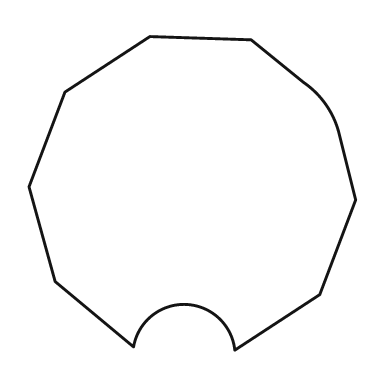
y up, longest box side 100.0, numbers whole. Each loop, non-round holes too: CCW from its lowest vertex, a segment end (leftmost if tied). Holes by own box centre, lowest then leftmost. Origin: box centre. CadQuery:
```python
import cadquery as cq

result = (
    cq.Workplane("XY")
    .moveTo(13.0, -48.0)
    .lineTo(39.0, -31.0)
    .lineTo(50.0, -2.0)
    .lineTo(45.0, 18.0)
    .threePointArc((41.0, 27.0), (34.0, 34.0))
    .lineTo(18.0, 47.0)
    .lineTo(-13.0, 48.0)
    .lineTo(-39.0, 31.0)
    .lineTo(-50.0, 2.0)
    .lineTo(-42.0, -27.0)
    .lineTo(-18.0, -47.0)
    .threePointArc((-2.0, -34.0), (13.0, -48.0))
    .close()
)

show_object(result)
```